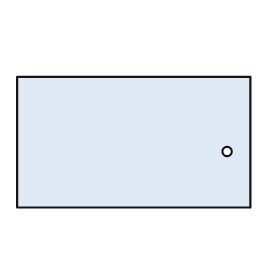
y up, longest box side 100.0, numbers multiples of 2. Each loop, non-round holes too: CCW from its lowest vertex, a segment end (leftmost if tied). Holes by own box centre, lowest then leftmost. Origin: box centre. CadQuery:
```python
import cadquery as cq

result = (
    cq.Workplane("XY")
    .moveTo(-50.0, -28.0)
    .lineTo(50.0, -28.0)
    .lineTo(50.0, 28.0)
    .lineTo(-50.0, 28.0)
    .close()
    .moveTo(40.0, -4.0)
    .circle(2.0)
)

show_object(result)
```